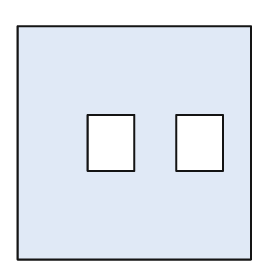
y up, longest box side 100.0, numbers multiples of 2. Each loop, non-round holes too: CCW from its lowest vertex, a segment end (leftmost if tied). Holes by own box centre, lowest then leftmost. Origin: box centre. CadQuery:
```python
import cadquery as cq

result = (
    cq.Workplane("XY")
    .moveTo(-50.0, -50.0)
    .lineTo(50.0, -50.0)
    .lineTo(50.0, 50.0)
    .lineTo(-50.0, 50.0)
    .close()
    .moveTo(-20.0, -12.0)
    .lineTo(0.0, -12.0)
    .lineTo(0.0, 12.0)
    .lineTo(-20.0, 12.0)
    .close()
    .moveTo(18.0, -12.0)
    .lineTo(38.0, -12.0)
    .lineTo(38.0, 12.0)
    .lineTo(18.0, 12.0)
    .close()
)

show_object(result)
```